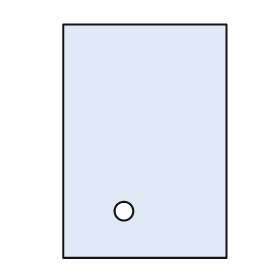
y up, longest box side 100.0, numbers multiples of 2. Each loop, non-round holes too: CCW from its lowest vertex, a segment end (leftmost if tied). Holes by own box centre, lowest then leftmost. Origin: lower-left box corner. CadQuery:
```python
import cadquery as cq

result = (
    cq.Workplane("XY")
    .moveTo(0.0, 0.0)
    .lineTo(70.0, 0.0)
    .lineTo(70.0, 100.0)
    .lineTo(0.0, 100.0)
    .close()
    .moveTo(26.0, 20.0)
    .circle(4.0)
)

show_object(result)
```